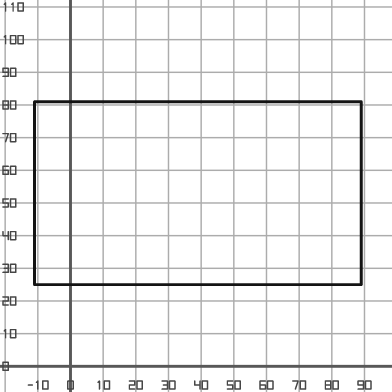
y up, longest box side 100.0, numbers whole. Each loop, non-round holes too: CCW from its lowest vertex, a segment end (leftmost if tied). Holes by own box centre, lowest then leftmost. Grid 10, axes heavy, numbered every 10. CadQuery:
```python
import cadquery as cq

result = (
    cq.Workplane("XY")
    .moveTo(-11.0, 25.0)
    .lineTo(89.0, 25.0)
    .lineTo(89.0, 81.0)
    .lineTo(-11.0, 81.0)
    .close()
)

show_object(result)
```